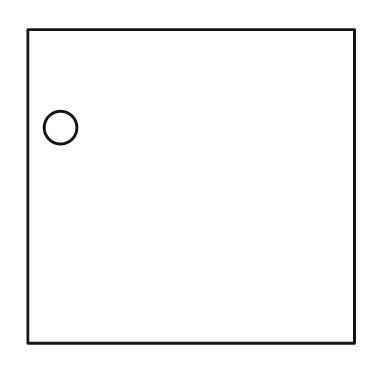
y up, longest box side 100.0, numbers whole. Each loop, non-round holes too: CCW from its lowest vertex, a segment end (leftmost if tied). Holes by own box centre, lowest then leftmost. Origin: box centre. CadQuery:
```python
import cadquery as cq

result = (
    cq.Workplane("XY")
    .moveTo(-50.0, -48.0)
    .lineTo(50.0, -48.0)
    .lineTo(50.0, 48.0)
    .lineTo(-50.0, 48.0)
    .close()
    .moveTo(-40.0, 18.0)
    .circle(5.0)
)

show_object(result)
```